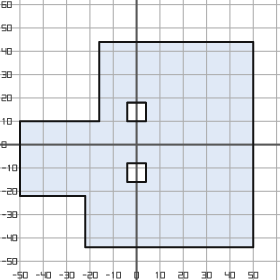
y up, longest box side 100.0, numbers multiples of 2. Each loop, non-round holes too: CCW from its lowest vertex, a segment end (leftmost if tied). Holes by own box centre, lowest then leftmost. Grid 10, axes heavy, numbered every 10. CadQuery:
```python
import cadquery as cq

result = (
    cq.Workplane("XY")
    .moveTo(-22.0, -44.0)
    .lineTo(50.0, -44.0)
    .lineTo(50.0, 44.0)
    .lineTo(-16.0, 44.0)
    .lineTo(-16.0, 10.0)
    .lineTo(-50.0, 10.0)
    .lineTo(-50.0, -22.0)
    .lineTo(-22.0, -22.0)
    .close()
    .moveTo(-4.0, -16.0)
    .lineTo(4.0, -16.0)
    .lineTo(4.0, -8.0)
    .lineTo(-4.0, -8.0)
    .close()
    .moveTo(-4.0, 10.0)
    .lineTo(4.0, 10.0)
    .lineTo(4.0, 18.0)
    .lineTo(-4.0, 18.0)
    .close()
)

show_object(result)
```